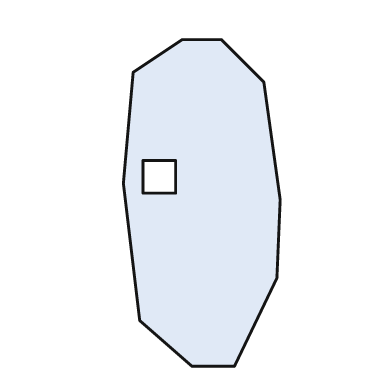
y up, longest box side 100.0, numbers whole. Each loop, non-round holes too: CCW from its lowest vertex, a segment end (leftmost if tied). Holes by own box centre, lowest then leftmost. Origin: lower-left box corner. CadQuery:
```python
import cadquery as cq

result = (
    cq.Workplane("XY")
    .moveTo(21.0, 0.0)
    .lineTo(34.0, 0.0)
    .lineTo(47.0, 27.0)
    .lineTo(48.0, 51.0)
    .lineTo(43.0, 87.0)
    .lineTo(30.0, 100.0)
    .lineTo(18.0, 100.0)
    .lineTo(3.0, 90.0)
    .lineTo(0.0, 56.0)
    .lineTo(5.0, 14.0)
    .close()
    .moveTo(6.0, 53.0)
    .lineTo(16.0, 53.0)
    .lineTo(16.0, 63.0)
    .lineTo(6.0, 63.0)
    .close()
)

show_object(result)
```